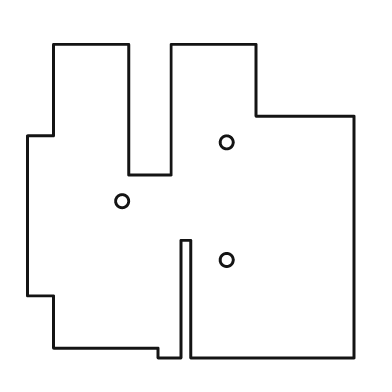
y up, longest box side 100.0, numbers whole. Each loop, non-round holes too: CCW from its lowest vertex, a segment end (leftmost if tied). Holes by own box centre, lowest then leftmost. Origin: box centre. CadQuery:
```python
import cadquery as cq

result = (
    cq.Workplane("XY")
    .moveTo(-10.0, -48.0)
    .lineTo(-3.0, -48.0)
    .lineTo(-3.0, -12.0)
    .lineTo(0.0, -12.0)
    .lineTo(0.0, -48.0)
    .lineTo(50.0, -48.0)
    .lineTo(50.0, 26.0)
    .lineTo(20.0, 26.0)
    .lineTo(20.0, 48.0)
    .lineTo(-6.0, 48.0)
    .lineTo(-6.0, 8.0)
    .lineTo(-19.0, 8.0)
    .lineTo(-19.0, 48.0)
    .lineTo(-42.0, 48.0)
    .lineTo(-42.0, 20.0)
    .lineTo(-50.0, 20.0)
    .lineTo(-50.0, -29.0)
    .lineTo(-42.0, -29.0)
    .lineTo(-42.0, -45.0)
    .lineTo(-10.0, -45.0)
    .close()
    .moveTo(11.0, -18.0)
    .circle(2.0)
    .moveTo(-21.0, 0.0)
    .circle(2.0)
    .moveTo(11.0, 18.0)
    .circle(2.0)
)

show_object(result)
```